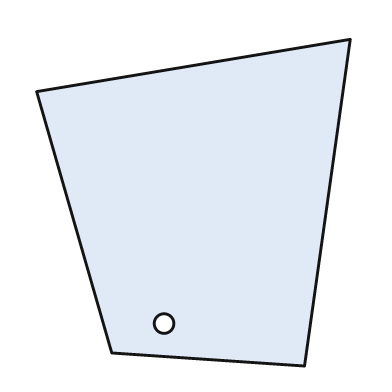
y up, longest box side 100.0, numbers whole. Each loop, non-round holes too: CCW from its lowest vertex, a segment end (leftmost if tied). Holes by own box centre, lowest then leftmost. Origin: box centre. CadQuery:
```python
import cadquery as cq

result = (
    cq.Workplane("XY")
    .moveTo(34.0, -50.0)
    .lineTo(48.0, 50.0)
    .lineTo(-48.0, 34.0)
    .lineTo(-25.0, -46.0)
    .close()
    .moveTo(-9.0, -37.0)
    .circle(3.0)
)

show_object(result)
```